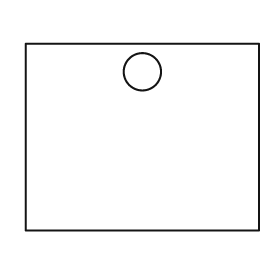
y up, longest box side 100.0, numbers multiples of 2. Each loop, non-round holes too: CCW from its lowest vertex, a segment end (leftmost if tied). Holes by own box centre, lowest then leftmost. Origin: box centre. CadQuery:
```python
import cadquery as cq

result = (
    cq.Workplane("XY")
    .moveTo(-50.0, -40.0)
    .lineTo(50.0, -40.0)
    .lineTo(50.0, 40.0)
    .lineTo(-50.0, 40.0)
    .close()
    .moveTo(0.0, 28.0)
    .circle(8.0)
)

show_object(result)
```